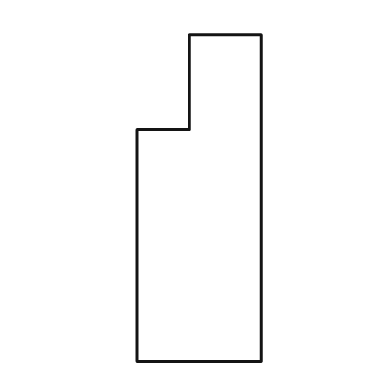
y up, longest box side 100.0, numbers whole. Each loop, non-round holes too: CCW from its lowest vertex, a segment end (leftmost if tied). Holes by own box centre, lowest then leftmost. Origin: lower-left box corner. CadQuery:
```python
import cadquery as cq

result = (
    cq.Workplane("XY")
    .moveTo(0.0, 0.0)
    .lineTo(38.0, 0.0)
    .lineTo(38.0, 100.0)
    .lineTo(16.0, 100.0)
    .lineTo(16.0, 71.0)
    .lineTo(0.0, 71.0)
    .close()
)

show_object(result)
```